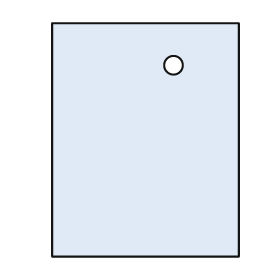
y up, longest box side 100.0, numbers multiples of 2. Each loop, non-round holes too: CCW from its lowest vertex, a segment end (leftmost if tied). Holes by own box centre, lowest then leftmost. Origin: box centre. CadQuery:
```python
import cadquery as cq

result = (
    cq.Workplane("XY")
    .moveTo(-40.0, -50.0)
    .lineTo(40.0, -50.0)
    .lineTo(40.0, 50.0)
    .lineTo(-40.0, 50.0)
    .close()
    .moveTo(12.0, 32.0)
    .circle(4.0)
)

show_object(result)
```